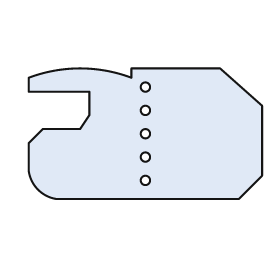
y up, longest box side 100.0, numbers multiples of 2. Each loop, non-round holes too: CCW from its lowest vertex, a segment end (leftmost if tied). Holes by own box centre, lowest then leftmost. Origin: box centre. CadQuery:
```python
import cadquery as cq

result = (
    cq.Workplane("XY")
    .moveTo(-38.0, -28.0)
    .lineTo(40.0, -28.0)
    .lineTo(50.0, -18.0)
    .lineTo(50.0, 12.0)
    .lineTo(32.0, 28.0)
    .lineTo(-6.0, 28.0)
    .lineTo(-6.0, 24.0)
    .threePointArc((-28.0, 28.0), (-50.0, 24.0))
    .lineTo(-50.0, 18.0)
    .lineTo(-24.0, 18.0)
    .lineTo(-24.0, 8.0)
    .lineTo(-28.0, 2.0)
    .lineTo(-44.0, 2.0)
    .lineTo(-50.0, -4.0)
    .lineTo(-50.0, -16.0)
    .threePointArc((-46.0, -24.0), (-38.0, -28.0))
    .close()
    .moveTo(0.0, -20.0)
    .circle(2.0)
    .moveTo(0.0, -10.0)
    .circle(2.0)
    .moveTo(0.0, 0.0)
    .circle(2.0)
    .moveTo(0.0, 10.0)
    .circle(2.0)
    .moveTo(0.0, 20.0)
    .circle(2.0)
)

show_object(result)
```